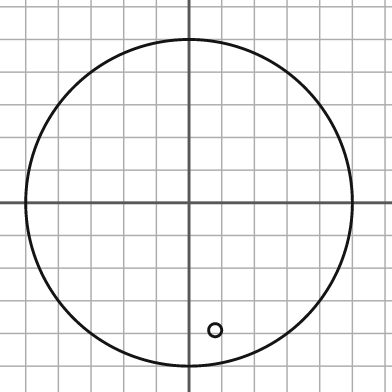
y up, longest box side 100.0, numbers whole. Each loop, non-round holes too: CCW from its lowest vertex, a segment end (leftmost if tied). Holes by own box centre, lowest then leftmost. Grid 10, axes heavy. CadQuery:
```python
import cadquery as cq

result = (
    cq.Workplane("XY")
    .moveTo(0.0, 0.0)
    .circle(50.0)
    .moveTo(8.0, -39.0)
    .circle(2.0)
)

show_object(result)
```